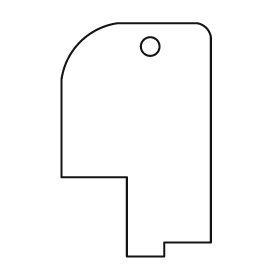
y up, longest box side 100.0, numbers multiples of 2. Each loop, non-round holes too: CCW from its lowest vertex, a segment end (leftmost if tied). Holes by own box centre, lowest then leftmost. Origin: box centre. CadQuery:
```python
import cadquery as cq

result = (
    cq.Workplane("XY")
    .moveTo(-4.0, -50.0)
    .lineTo(12.0, -50.0)
    .lineTo(12.0, -44.0)
    .lineTo(32.0, -44.0)
    .lineTo(32.0, 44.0)
    .threePointArc((30.0, 48.0), (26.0, 50.0))
    .lineTo(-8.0, 50.0)
    .threePointArc((-24.0, 42.0), (-32.0, 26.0))
    .lineTo(-32.0, -16.0)
    .lineTo(-4.0, -16.0)
    .close()
    .moveTo(6.0, 40.0)
    .circle(4.0)
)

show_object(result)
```